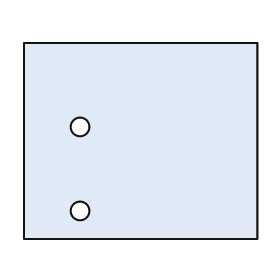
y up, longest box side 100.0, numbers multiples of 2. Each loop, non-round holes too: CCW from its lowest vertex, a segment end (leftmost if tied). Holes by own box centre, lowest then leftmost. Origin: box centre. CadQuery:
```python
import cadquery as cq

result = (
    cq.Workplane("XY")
    .moveTo(-50.0, -42.0)
    .lineTo(50.0, -42.0)
    .lineTo(50.0, 42.0)
    .lineTo(-50.0, 42.0)
    .close()
    .moveTo(-26.0, -30.0)
    .circle(4.0)
    .moveTo(-26.0, 6.0)
    .circle(4.0)
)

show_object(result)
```